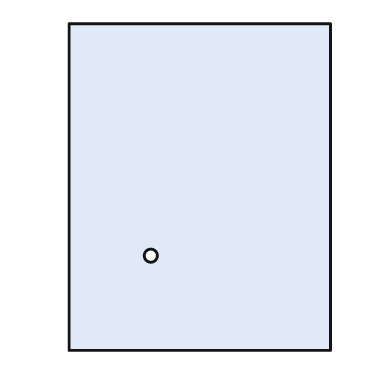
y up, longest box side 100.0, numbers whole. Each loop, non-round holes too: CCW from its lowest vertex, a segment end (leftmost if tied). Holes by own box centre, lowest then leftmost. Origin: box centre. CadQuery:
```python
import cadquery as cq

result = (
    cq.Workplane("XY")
    .moveTo(-40.0, -50.0)
    .lineTo(40.0, -50.0)
    .lineTo(40.0, 50.0)
    .lineTo(-40.0, 50.0)
    .close()
    .moveTo(-15.0, -21.0)
    .circle(2.0)
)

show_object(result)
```